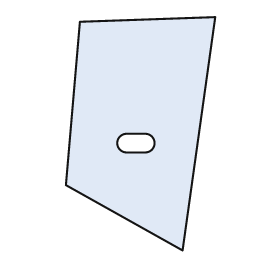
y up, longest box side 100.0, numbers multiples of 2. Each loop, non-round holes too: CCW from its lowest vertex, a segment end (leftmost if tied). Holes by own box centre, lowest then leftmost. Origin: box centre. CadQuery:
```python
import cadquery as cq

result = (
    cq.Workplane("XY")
    .moveTo(18.0, -50.0)
    .lineTo(32.0, 50.0)
    .lineTo(-26.0, 48.0)
    .lineTo(-32.0, -22.0)
    .close()
    .moveTo(-6.0, -8.0)
    .lineTo(2.0, -8.0)
    .threePointArc((6.0, -4.0), (2.0, 0.0))
    .lineTo(-6.0, 0.0)
    .threePointArc((-10.0, -4.0), (-6.0, -8.0))
    .close()
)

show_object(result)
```